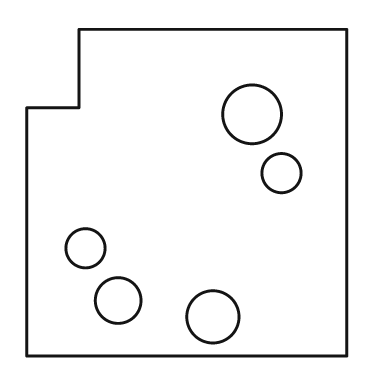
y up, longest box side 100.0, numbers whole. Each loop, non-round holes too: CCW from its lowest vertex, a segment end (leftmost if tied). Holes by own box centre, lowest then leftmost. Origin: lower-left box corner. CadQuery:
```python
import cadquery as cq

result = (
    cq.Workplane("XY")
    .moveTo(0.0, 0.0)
    .lineTo(98.0, 0.0)
    .lineTo(98.0, 100.0)
    .lineTo(16.0, 100.0)
    .lineTo(16.0, 76.0)
    .lineTo(0.0, 76.0)
    .close()
    .moveTo(57.0, 12.0)
    .circle(8.0)
    .moveTo(28.0, 17.0)
    .circle(7.0)
    .moveTo(18.0, 33.0)
    .circle(6.0)
    .moveTo(78.0, 56.0)
    .circle(6.0)
    .moveTo(69.0, 74.0)
    .circle(9.0)
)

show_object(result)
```